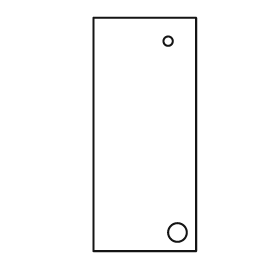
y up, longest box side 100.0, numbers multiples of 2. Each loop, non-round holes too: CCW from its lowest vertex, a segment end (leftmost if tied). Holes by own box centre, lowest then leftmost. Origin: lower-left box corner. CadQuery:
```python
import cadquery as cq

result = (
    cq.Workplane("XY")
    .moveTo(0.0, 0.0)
    .lineTo(44.0, 0.0)
    .lineTo(44.0, 100.0)
    .lineTo(0.0, 100.0)
    .close()
    .moveTo(36.0, 8.0)
    .circle(4.0)
    .moveTo(32.0, 90.0)
    .circle(2.0)
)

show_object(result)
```